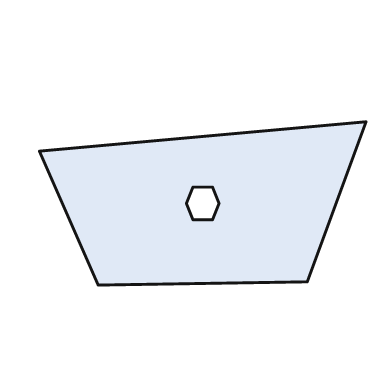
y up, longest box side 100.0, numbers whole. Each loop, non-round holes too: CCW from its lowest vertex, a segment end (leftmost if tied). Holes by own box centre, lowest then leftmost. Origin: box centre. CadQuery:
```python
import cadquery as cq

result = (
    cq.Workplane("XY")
    .moveTo(-32.0, -25.0)
    .lineTo(32.0, -24.0)
    .lineTo(50.0, 25.0)
    .lineTo(-50.0, 16.0)
    .close()
    .moveTo(-3.0, -5.0)
    .lineTo(3.0, -5.0)
    .lineTo(5.0, 0.0)
    .lineTo(3.0, 5.0)
    .lineTo(-3.0, 5.0)
    .lineTo(-5.0, 0.0)
    .close()
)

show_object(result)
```